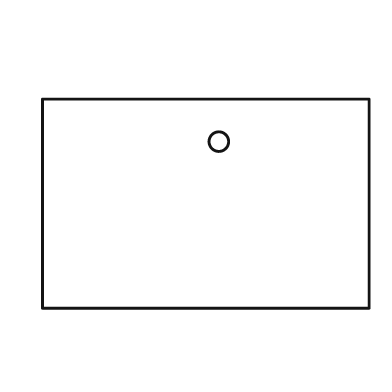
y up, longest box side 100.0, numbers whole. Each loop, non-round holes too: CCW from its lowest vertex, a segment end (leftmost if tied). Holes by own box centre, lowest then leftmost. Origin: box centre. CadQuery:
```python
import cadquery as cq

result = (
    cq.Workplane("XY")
    .moveTo(-50.0, -32.0)
    .lineTo(50.0, -32.0)
    .lineTo(50.0, 32.0)
    .lineTo(-50.0, 32.0)
    .close()
    .moveTo(4.0, 19.0)
    .circle(3.0)
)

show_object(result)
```